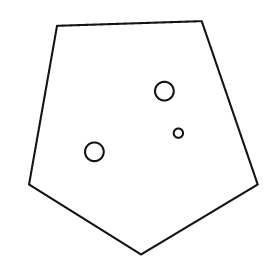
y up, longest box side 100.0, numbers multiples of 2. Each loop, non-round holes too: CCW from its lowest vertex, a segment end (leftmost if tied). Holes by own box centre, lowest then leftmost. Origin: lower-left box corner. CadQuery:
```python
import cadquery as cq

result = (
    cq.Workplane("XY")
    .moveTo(48.0, 0.0)
    .lineTo(98.0, 30.0)
    .lineTo(74.0, 100.0)
    .lineTo(12.0, 98.0)
    .lineTo(0.0, 30.0)
    .close()
    .moveTo(28.0, 44.0)
    .circle(4.0)
    .moveTo(64.0, 52.0)
    .circle(2.0)
    .moveTo(58.0, 70.0)
    .circle(4.0)
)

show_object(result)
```